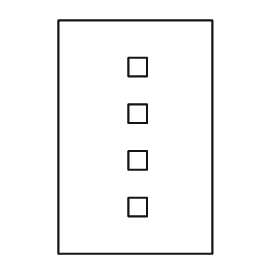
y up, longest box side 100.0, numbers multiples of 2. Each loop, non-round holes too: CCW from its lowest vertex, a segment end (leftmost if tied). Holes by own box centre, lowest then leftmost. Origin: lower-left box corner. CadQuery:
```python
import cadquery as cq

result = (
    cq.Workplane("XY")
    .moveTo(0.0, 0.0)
    .lineTo(66.0, 0.0)
    .lineTo(66.0, 100.0)
    .lineTo(0.0, 100.0)
    .close()
    .moveTo(30.0, 16.0)
    .lineTo(38.0, 16.0)
    .lineTo(38.0, 24.0)
    .lineTo(30.0, 24.0)
    .close()
    .moveTo(30.0, 36.0)
    .lineTo(38.0, 36.0)
    .lineTo(38.0, 44.0)
    .lineTo(30.0, 44.0)
    .close()
    .moveTo(30.0, 56.0)
    .lineTo(38.0, 56.0)
    .lineTo(38.0, 64.0)
    .lineTo(30.0, 64.0)
    .close()
    .moveTo(30.0, 76.0)
    .lineTo(38.0, 76.0)
    .lineTo(38.0, 84.0)
    .lineTo(30.0, 84.0)
    .close()
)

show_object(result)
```